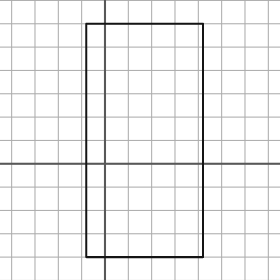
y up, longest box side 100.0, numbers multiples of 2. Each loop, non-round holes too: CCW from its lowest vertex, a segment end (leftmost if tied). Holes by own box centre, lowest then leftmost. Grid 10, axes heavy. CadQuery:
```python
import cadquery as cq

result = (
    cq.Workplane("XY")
    .moveTo(-8.0, -40.0)
    .lineTo(42.0, -40.0)
    .lineTo(42.0, 60.0)
    .lineTo(-8.0, 60.0)
    .close()
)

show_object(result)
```